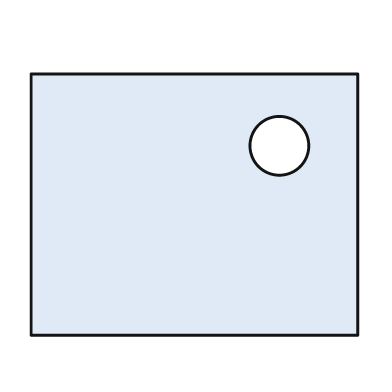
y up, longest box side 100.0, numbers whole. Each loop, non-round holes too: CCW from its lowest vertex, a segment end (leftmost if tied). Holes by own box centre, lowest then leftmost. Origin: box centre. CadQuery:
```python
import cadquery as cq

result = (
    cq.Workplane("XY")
    .moveTo(-50.0, -40.0)
    .lineTo(50.0, -40.0)
    .lineTo(50.0, 40.0)
    .lineTo(-50.0, 40.0)
    .close()
    .moveTo(26.0, 18.0)
    .circle(9.0)
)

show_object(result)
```